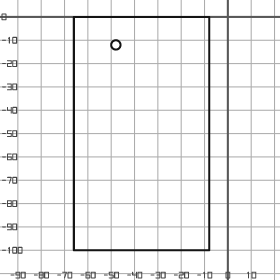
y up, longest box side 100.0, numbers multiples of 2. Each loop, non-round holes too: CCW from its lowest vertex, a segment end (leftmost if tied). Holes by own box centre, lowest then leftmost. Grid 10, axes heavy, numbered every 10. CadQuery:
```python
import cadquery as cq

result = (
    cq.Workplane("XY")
    .moveTo(-66.0, -100.0)
    .lineTo(-8.0, -100.0)
    .lineTo(-8.0, 0.0)
    .lineTo(-66.0, 0.0)
    .close()
    .moveTo(-48.0, -12.0)
    .circle(2.0)
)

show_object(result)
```